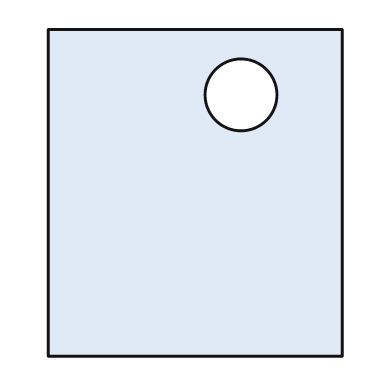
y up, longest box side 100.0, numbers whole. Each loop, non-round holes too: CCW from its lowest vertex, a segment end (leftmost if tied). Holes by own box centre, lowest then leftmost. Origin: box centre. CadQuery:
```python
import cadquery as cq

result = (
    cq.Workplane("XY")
    .moveTo(-45.0, -50.0)
    .lineTo(45.0, -50.0)
    .lineTo(45.0, 50.0)
    .lineTo(-45.0, 50.0)
    .close()
    .moveTo(14.0, 30.0)
    .circle(11.0)
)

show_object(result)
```